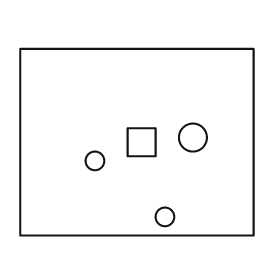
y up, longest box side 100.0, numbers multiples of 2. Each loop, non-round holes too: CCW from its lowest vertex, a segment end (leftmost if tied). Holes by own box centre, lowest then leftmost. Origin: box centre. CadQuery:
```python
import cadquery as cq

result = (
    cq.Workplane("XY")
    .moveTo(-50.0, -40.0)
    .lineTo(50.0, -40.0)
    .lineTo(50.0, 40.0)
    .lineTo(-50.0, 40.0)
    .close()
    .moveTo(12.0, -32.0)
    .circle(4.0)
    .moveTo(-18.0, -8.0)
    .circle(4.0)
    .moveTo(-4.0, -6.0)
    .lineTo(8.0, -6.0)
    .lineTo(8.0, 6.0)
    .lineTo(-4.0, 6.0)
    .close()
    .moveTo(24.0, 2.0)
    .circle(6.0)
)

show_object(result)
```